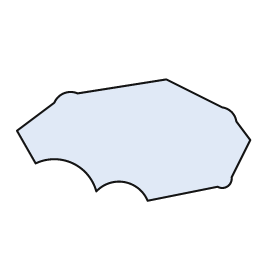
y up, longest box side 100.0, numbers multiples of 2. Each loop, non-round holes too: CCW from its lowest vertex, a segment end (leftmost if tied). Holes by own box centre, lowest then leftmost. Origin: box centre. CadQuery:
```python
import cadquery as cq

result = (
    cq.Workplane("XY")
    .moveTo(6.0, -26.0)
    .lineTo(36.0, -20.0)
    .threePointArc((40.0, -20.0), (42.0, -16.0))
    .lineTo(50.0, 0.0)
    .lineTo(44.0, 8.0)
    .threePointArc((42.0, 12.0), (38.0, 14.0))
    .lineTo(14.0, 26.0)
    .lineTo(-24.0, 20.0)
    .threePointArc((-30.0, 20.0), (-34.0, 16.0))
    .lineTo(-50.0, 4.0)
    .lineTo(-42.0, -10.0)
    .threePointArc((-26.0, -10.0), (-16.0, -22.0))
    .threePointArc((-4.0, -18.0), (6.0, -26.0))
    .close()
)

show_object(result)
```